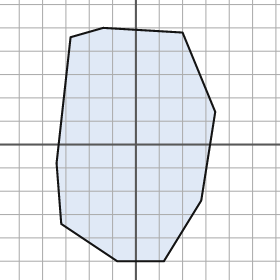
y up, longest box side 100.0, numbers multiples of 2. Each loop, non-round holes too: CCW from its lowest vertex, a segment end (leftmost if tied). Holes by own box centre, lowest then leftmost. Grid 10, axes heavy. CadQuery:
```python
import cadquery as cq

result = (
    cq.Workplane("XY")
    .moveTo(-8.0, -50.0)
    .lineTo(12.0, -50.0)
    .lineTo(28.0, -24.0)
    .lineTo(34.0, 14.0)
    .lineTo(20.0, 48.0)
    .lineTo(-14.0, 50.0)
    .lineTo(-28.0, 46.0)
    .lineTo(-34.0, -8.0)
    .lineTo(-32.0, -34.0)
    .close()
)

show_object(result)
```